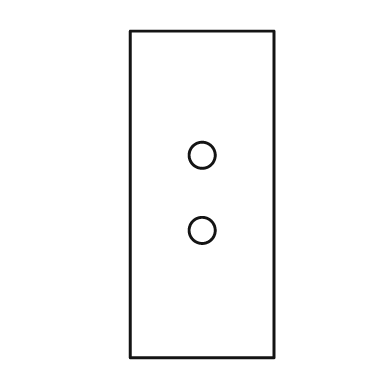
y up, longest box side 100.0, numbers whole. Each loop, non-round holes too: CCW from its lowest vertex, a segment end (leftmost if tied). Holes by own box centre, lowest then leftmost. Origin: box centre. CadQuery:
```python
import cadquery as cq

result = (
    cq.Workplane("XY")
    .moveTo(-22.0, -50.0)
    .lineTo(22.0, -50.0)
    .lineTo(22.0, 50.0)
    .lineTo(-22.0, 50.0)
    .close()
    .moveTo(0.0, -11.0)
    .circle(4.0)
    .moveTo(0.0, 12.0)
    .circle(4.0)
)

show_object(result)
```